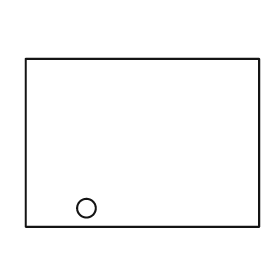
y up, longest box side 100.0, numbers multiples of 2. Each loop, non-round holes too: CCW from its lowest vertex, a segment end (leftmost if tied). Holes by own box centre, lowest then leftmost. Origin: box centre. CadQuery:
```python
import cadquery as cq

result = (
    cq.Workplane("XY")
    .moveTo(-50.0, -36.0)
    .lineTo(50.0, -36.0)
    .lineTo(50.0, 36.0)
    .lineTo(-50.0, 36.0)
    .close()
    .moveTo(-24.0, -28.0)
    .circle(4.0)
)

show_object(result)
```